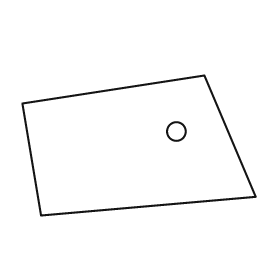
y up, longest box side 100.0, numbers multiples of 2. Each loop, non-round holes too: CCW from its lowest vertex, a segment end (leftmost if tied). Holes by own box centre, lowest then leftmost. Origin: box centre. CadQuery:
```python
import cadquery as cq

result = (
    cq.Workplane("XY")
    .moveTo(-42.0, -30.0)
    .lineTo(50.0, -22.0)
    .lineTo(28.0, 30.0)
    .lineTo(-50.0, 18.0)
    .close()
    .moveTo(16.0, 6.0)
    .circle(4.0)
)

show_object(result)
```